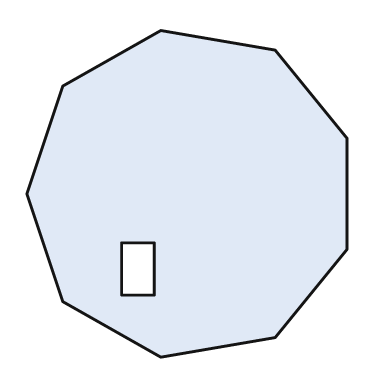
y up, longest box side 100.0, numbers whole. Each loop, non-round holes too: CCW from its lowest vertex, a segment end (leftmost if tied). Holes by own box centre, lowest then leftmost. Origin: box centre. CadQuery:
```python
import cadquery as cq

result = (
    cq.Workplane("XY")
    .moveTo(-8.0, -50.0)
    .lineTo(27.0, -44.0)
    .lineTo(49.0, -17.0)
    .lineTo(49.0, 17.0)
    .lineTo(27.0, 44.0)
    .lineTo(-8.0, 50.0)
    .lineTo(-38.0, 33.0)
    .lineTo(-49.0, 0.0)
    .lineTo(-38.0, -33.0)
    .close()
    .moveTo(-20.0, -31.0)
    .lineTo(-10.0, -31.0)
    .lineTo(-10.0, -15.0)
    .lineTo(-20.0, -15.0)
    .close()
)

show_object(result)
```